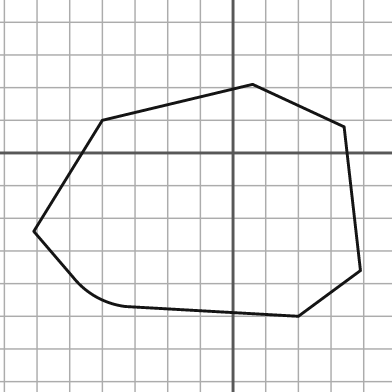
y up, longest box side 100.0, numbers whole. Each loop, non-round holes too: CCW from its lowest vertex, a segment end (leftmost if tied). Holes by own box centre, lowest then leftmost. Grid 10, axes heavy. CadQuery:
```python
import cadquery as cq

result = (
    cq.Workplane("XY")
    .moveTo(20.0, -50.0)
    .lineTo(39.0, -36.0)
    .lineTo(34.0, 8.0)
    .lineTo(6.0, 21.0)
    .lineTo(-40.0, 10.0)
    .lineTo(-61.0, -24.0)
    .lineTo(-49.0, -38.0)
    .threePointArc((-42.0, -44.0), (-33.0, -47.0))
    .close()
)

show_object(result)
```